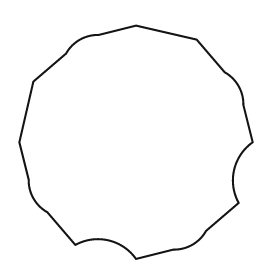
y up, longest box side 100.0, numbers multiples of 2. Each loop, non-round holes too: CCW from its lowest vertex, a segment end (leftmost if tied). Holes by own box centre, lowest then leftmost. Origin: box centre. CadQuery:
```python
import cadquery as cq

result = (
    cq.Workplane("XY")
    .moveTo(0.0, -50.0)
    .lineTo(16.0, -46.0)
    .threePointArc((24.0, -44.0), (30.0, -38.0))
    .lineTo(44.0, -26.0)
    .threePointArc((42.0, -12.0), (50.0, 0.0))
    .lineTo(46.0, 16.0)
    .threePointArc((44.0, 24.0), (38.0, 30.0))
    .lineTo(26.0, 44.0)
    .lineTo(0.0, 50.0)
    .lineTo(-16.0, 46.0)
    .threePointArc((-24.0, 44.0), (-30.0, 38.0))
    .lineTo(-44.0, 26.0)
    .lineTo(-50.0, 0.0)
    .lineTo(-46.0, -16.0)
    .threePointArc((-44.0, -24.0), (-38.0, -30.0))
    .lineTo(-26.0, -44.0)
    .threePointArc((-12.0, -42.0), (0.0, -50.0))
    .close()
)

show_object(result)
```